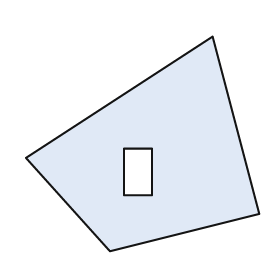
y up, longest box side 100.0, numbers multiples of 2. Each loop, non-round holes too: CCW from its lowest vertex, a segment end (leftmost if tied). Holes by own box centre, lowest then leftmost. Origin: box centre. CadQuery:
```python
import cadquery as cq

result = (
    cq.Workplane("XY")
    .moveTo(-14.0, -46.0)
    .lineTo(50.0, -30.0)
    .lineTo(30.0, 46.0)
    .lineTo(-50.0, -6.0)
    .close()
    .moveTo(-8.0, -22.0)
    .lineTo(4.0, -22.0)
    .lineTo(4.0, -2.0)
    .lineTo(-8.0, -2.0)
    .close()
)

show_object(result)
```